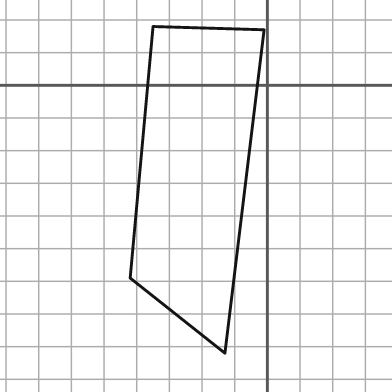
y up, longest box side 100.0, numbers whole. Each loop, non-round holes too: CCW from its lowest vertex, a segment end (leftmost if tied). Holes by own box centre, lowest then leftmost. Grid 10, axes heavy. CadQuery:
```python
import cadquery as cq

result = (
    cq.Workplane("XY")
    .moveTo(-13.0, -82.0)
    .lineTo(-1.0, 17.0)
    .lineTo(-35.0, 18.0)
    .lineTo(-42.0, -59.0)
    .close()
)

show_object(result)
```